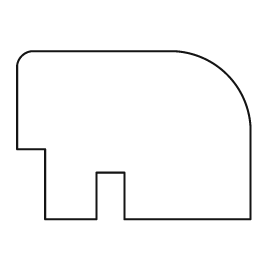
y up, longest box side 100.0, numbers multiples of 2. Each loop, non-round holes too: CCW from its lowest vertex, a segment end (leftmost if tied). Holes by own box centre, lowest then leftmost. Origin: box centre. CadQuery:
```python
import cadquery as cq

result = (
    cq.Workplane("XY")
    .moveTo(-38.0, -36.0)
    .lineTo(-16.0, -36.0)
    .lineTo(-16.0, -16.0)
    .lineTo(-4.0, -16.0)
    .lineTo(-4.0, -36.0)
    .lineTo(50.0, -36.0)
    .lineTo(50.0, 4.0)
    .threePointArc((40.0, 26.0), (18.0, 36.0))
    .lineTo(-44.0, 36.0)
    .threePointArc((-48.0, 34.0), (-50.0, 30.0))
    .lineTo(-50.0, -6.0)
    .lineTo(-38.0, -6.0)
    .close()
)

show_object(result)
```